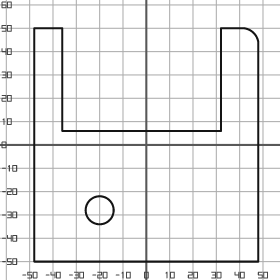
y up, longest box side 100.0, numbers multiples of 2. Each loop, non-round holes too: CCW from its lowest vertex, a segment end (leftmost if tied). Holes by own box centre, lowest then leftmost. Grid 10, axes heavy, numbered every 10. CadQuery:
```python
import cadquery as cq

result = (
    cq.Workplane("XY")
    .moveTo(-48.0, -50.0)
    .lineTo(48.0, -50.0)
    .lineTo(48.0, 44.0)
    .threePointArc((46.0, 48.0), (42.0, 50.0))
    .lineTo(32.0, 50.0)
    .lineTo(32.0, 6.0)
    .lineTo(-36.0, 6.0)
    .lineTo(-36.0, 50.0)
    .lineTo(-48.0, 50.0)
    .close()
    .moveTo(-20.0, -28.0)
    .circle(6.0)
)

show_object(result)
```